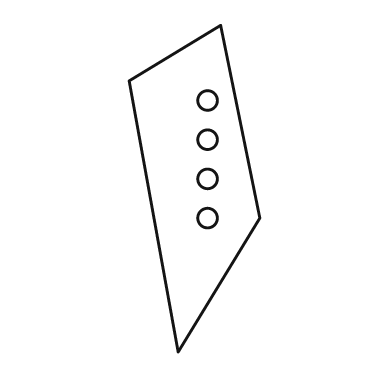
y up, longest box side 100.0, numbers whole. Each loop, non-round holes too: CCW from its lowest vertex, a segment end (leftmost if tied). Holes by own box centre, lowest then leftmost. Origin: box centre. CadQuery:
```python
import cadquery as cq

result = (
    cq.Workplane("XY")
    .moveTo(-5.0, -50.0)
    .lineTo(20.0, -9.0)
    .lineTo(8.0, 50.0)
    .lineTo(-20.0, 33.0)
    .close()
    .moveTo(4.0, -9.0)
    .circle(3.0)
    .moveTo(4.0, 3.0)
    .circle(3.0)
    .moveTo(4.0, 15.0)
    .circle(3.0)
    .moveTo(4.0, 27.0)
    .circle(3.0)
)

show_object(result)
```